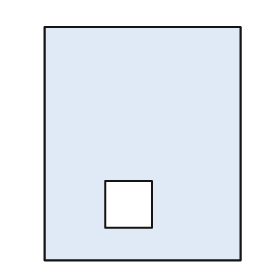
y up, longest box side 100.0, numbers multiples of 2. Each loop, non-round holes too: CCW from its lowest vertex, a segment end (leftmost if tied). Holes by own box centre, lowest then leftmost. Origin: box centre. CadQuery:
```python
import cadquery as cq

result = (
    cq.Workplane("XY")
    .moveTo(-42.0, -50.0)
    .lineTo(42.0, -50.0)
    .lineTo(42.0, 50.0)
    .lineTo(-42.0, 50.0)
    .close()
    .moveTo(-16.0, -36.0)
    .lineTo(4.0, -36.0)
    .lineTo(4.0, -16.0)
    .lineTo(-16.0, -16.0)
    .close()
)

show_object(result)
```